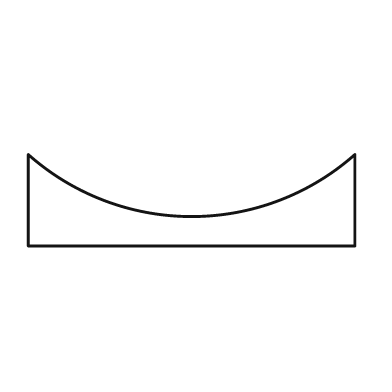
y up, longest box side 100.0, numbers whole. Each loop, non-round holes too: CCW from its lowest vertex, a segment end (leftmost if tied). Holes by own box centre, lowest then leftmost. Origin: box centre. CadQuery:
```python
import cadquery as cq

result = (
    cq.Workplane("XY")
    .moveTo(-50.0, -14.0)
    .lineTo(50.0, -14.0)
    .lineTo(50.0, 14.0)
    .threePointArc((0.0, -5.0), (-50.0, 14.0))
    .close()
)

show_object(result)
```